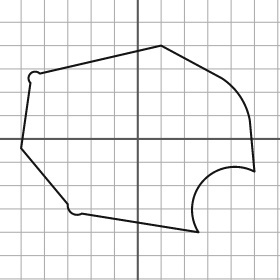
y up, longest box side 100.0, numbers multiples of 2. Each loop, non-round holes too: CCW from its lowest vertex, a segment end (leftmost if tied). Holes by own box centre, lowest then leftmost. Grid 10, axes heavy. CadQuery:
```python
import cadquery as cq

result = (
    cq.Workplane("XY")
    .moveTo(26.0, -40.0)
    .threePointArc((28.0, -18.0), (50.0, -14.0))
    .lineTo(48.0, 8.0)
    .threePointArc((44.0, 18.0), (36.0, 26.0))
    .lineTo(10.0, 40.0)
    .lineTo(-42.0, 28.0)
    .threePointArc((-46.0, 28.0), (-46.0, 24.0))
    .lineTo(-50.0, -4.0)
    .lineTo(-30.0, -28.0)
    .threePointArc((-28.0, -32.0), (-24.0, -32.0))
    .close()
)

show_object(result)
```